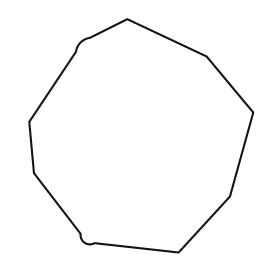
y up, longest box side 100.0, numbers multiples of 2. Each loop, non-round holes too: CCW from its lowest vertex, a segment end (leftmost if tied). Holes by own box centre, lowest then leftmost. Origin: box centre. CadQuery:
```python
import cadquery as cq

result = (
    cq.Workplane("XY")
    .moveTo(16.0, -50.0)
    .lineTo(38.0, -26.0)
    .lineTo(48.0, 10.0)
    .lineTo(28.0, 34.0)
    .lineTo(-6.0, 50.0)
    .lineTo(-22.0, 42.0)
    .threePointArc((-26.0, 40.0), (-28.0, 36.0))
    .lineTo(-48.0, 6.0)
    .lineTo(-46.0, -16.0)
    .lineTo(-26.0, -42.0)
    .threePointArc((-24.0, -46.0), (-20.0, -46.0))
    .close()
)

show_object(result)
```